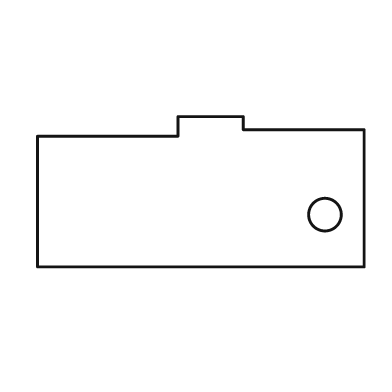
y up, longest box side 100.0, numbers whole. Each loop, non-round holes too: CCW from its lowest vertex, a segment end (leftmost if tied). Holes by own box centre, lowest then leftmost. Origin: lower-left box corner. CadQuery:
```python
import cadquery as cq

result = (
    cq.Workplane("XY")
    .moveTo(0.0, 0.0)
    .lineTo(100.0, 0.0)
    .lineTo(100.0, 42.0)
    .lineTo(63.0, 42.0)
    .lineTo(63.0, 46.0)
    .lineTo(43.0, 46.0)
    .lineTo(43.0, 40.0)
    .lineTo(0.0, 40.0)
    .close()
    .moveTo(88.0, 16.0)
    .circle(5.0)
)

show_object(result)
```